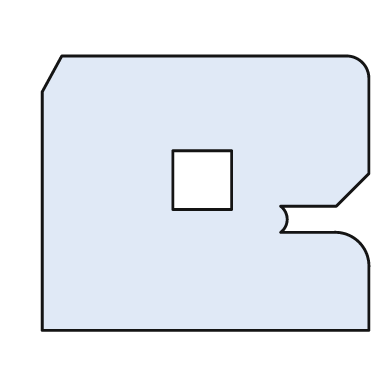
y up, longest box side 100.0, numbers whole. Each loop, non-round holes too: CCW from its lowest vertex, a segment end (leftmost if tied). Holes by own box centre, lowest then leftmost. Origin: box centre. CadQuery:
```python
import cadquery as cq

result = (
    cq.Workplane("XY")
    .moveTo(-50.0, -42.0)
    .lineTo(50.0, -42.0)
    .lineTo(50.0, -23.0)
    .threePointArc((47.0, -15.0), (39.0, -12.0))
    .lineTo(23.0, -12.0)
    .threePointArc((25.0, -8.0), (23.0, -4.0))
    .lineTo(40.0, -4.0)
    .lineTo(50.0, 6.0)
    .lineTo(50.0, 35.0)
    .threePointArc((48.0, 40.0), (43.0, 42.0))
    .lineTo(-44.0, 42.0)
    .lineTo(-50.0, 31.0)
    .close()
    .moveTo(-10.0, -5.0)
    .lineTo(8.0, -5.0)
    .lineTo(8.0, 13.0)
    .lineTo(-10.0, 13.0)
    .close()
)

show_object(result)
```